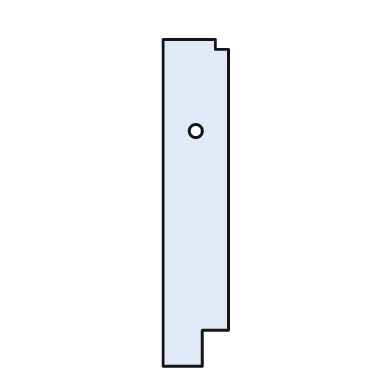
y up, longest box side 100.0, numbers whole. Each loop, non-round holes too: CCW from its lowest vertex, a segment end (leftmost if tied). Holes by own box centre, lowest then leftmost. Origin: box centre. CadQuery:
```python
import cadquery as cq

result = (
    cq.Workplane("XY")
    .moveTo(-10.0, -50.0)
    .lineTo(2.0, -50.0)
    .lineTo(2.0, -39.0)
    .lineTo(10.0, -39.0)
    .lineTo(10.0, 47.0)
    .lineTo(6.0, 47.0)
    .lineTo(6.0, 50.0)
    .lineTo(-10.0, 50.0)
    .close()
    .moveTo(0.0, 22.0)
    .circle(2.0)
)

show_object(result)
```